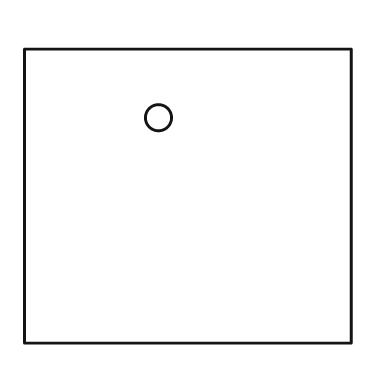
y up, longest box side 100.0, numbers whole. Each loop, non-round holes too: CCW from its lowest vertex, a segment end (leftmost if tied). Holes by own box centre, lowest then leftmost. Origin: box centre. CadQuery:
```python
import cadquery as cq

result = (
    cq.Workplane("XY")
    .moveTo(-50.0, -45.0)
    .lineTo(50.0, -45.0)
    .lineTo(50.0, 45.0)
    .lineTo(-50.0, 45.0)
    .close()
    .moveTo(-9.0, 24.0)
    .circle(4.0)
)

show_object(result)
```